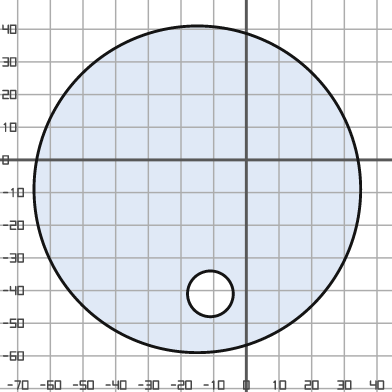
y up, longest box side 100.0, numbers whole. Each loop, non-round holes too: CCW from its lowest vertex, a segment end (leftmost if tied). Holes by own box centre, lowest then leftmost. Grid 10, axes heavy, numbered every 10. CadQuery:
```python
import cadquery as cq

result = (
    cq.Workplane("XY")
    .moveTo(-15.0, -9.0)
    .circle(50.0)
    .moveTo(-11.0, -41.0)
    .circle(7.0)
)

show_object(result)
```